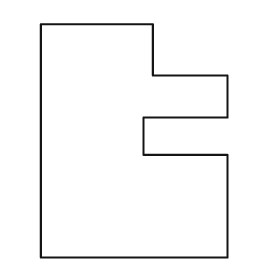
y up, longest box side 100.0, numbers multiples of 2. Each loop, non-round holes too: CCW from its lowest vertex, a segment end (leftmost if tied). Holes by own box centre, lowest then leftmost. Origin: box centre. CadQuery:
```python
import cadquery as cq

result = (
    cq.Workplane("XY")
    .moveTo(-40.0, -50.0)
    .lineTo(40.0, -50.0)
    .lineTo(40.0, -6.0)
    .lineTo(4.0, -6.0)
    .lineTo(4.0, 10.0)
    .lineTo(40.0, 10.0)
    .lineTo(40.0, 28.0)
    .lineTo(8.0, 28.0)
    .lineTo(8.0, 50.0)
    .lineTo(-40.0, 50.0)
    .close()
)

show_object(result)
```